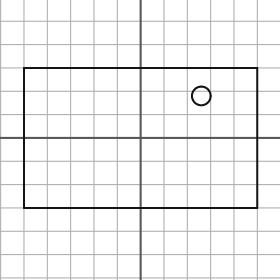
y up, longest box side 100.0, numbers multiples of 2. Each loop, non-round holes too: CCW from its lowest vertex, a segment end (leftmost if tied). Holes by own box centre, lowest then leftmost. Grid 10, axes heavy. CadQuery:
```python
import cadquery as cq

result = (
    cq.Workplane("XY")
    .moveTo(-50.0, -30.0)
    .lineTo(50.0, -30.0)
    .lineTo(50.0, 30.0)
    .lineTo(-50.0, 30.0)
    .close()
    .moveTo(26.0, 18.0)
    .circle(4.0)
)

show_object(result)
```